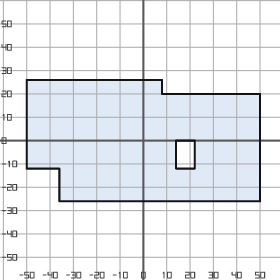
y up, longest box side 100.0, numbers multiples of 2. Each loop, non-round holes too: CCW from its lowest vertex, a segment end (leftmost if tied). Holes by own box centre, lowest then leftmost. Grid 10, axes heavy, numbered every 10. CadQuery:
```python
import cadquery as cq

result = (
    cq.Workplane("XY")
    .moveTo(-36.0, -26.0)
    .lineTo(50.0, -26.0)
    .lineTo(50.0, 20.0)
    .lineTo(8.0, 20.0)
    .lineTo(8.0, 26.0)
    .lineTo(-50.0, 26.0)
    .lineTo(-50.0, -12.0)
    .lineTo(-36.0, -12.0)
    .close()
    .moveTo(14.0, -12.0)
    .lineTo(22.0, -12.0)
    .lineTo(22.0, 0.0)
    .lineTo(14.0, 0.0)
    .close()
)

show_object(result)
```